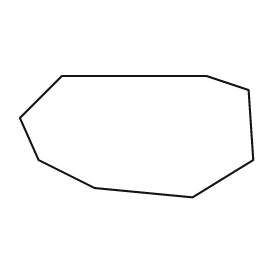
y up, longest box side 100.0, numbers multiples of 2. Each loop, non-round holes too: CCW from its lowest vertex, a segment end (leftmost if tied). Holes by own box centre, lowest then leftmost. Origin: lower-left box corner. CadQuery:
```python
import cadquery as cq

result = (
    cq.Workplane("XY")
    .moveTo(74.0, 0.0)
    .lineTo(100.0, 16.0)
    .lineTo(98.0, 46.0)
    .lineTo(80.0, 52.0)
    .lineTo(18.0, 52.0)
    .lineTo(0.0, 34.0)
    .lineTo(8.0, 16.0)
    .lineTo(32.0, 4.0)
    .close()
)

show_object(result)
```